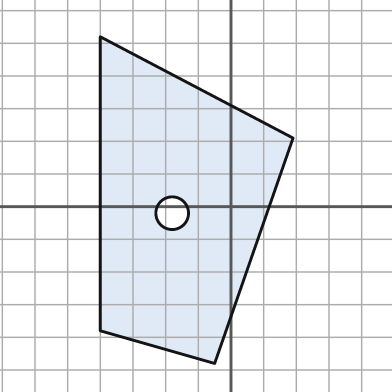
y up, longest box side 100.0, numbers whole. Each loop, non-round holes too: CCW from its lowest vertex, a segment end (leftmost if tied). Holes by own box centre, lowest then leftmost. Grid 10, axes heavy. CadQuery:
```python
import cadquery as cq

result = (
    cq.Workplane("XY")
    .moveTo(-5.0, -48.0)
    .lineTo(19.0, 21.0)
    .lineTo(-40.0, 52.0)
    .lineTo(-40.0, -38.0)
    .close()
    .moveTo(-18.0, -2.0)
    .circle(5.0)
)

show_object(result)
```